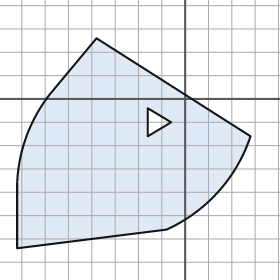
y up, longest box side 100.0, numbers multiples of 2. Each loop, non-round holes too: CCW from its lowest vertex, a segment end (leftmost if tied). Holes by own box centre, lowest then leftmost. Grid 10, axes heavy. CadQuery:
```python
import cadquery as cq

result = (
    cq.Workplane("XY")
    .moveTo(-72.0, -64.0)
    .lineTo(-8.0, -56.0)
    .threePointArc((14.0, -40.0), (28.0, -16.0))
    .lineTo(-38.0, 26.0)
    .lineTo(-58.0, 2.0)
    .threePointArc((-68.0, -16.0), (-72.0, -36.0))
    .close()
    .moveTo(-16.0, -16.0)
    .lineTo(-6.0, -10.0)
    .lineTo(-16.0, -4.0)
    .close()
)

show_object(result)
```